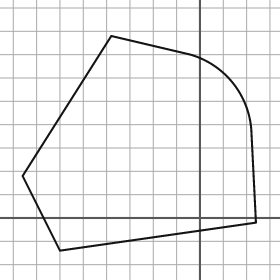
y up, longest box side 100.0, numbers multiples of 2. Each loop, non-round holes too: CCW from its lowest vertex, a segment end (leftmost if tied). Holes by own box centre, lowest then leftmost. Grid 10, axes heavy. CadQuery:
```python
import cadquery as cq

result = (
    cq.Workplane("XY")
    .moveTo(-60.0, -14.0)
    .lineTo(24.0, -2.0)
    .lineTo(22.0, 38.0)
    .threePointArc((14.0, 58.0), (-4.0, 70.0))
    .lineTo(-38.0, 78.0)
    .lineTo(-76.0, 18.0)
    .close()
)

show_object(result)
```